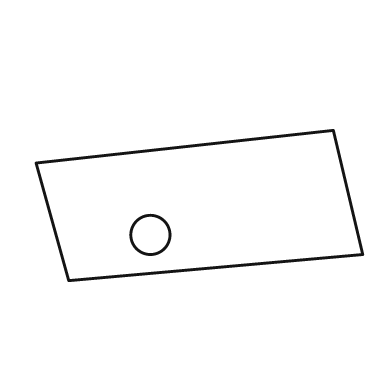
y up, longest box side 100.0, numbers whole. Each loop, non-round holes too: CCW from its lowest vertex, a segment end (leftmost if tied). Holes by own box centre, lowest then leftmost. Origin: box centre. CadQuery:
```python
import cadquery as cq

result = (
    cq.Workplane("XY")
    .moveTo(-40.0, -23.0)
    .lineTo(50.0, -15.0)
    .lineTo(41.0, 23.0)
    .lineTo(-50.0, 13.0)
    .close()
    .moveTo(-15.0, -9.0)
    .circle(6.0)
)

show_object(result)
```